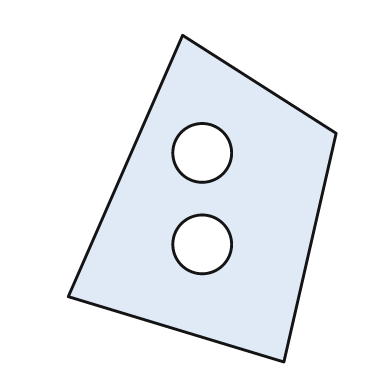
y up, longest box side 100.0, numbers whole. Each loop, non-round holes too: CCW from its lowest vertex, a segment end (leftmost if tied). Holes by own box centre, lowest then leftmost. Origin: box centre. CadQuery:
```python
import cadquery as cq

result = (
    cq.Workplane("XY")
    .moveTo(25.0, -50.0)
    .lineTo(41.0, 20.0)
    .lineTo(-6.0, 50.0)
    .lineTo(-41.0, -30.0)
    .close()
    .moveTo(0.0, -14.0)
    .circle(9.0)
    .moveTo(0.0, 14.0)
    .circle(9.0)
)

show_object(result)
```